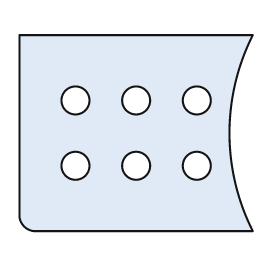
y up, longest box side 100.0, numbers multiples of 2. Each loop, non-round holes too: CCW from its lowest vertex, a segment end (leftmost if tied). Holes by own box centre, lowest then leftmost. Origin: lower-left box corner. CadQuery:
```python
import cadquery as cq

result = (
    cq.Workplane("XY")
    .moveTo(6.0, 0.0)
    .lineTo(100.0, 0.0)
    .threePointArc((90.0, 42.0), (100.0, 84.0))
    .lineTo(0.0, 84.0)
    .lineTo(0.0, 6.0)
    .threePointArc((2.0, 2.0), (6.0, 0.0))
    .close()
    .moveTo(24.0, 28.0)
    .circle(6.0)
    .moveTo(50.0, 28.0)
    .circle(6.0)
    .moveTo(76.0, 28.0)
    .circle(6.0)
    .moveTo(24.0, 56.0)
    .circle(6.0)
    .moveTo(50.0, 56.0)
    .circle(6.0)
    .moveTo(76.0, 56.0)
    .circle(6.0)
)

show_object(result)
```